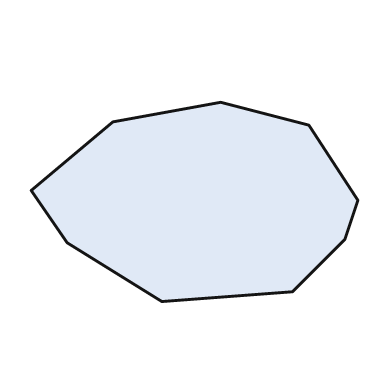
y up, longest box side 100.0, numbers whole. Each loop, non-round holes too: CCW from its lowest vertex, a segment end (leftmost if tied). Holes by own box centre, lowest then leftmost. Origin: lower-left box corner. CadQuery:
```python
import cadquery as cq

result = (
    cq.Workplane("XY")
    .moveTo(40.0, 0.0)
    .lineTo(80.0, 3.0)
    .lineTo(96.0, 19.0)
    .lineTo(100.0, 31.0)
    .lineTo(85.0, 54.0)
    .lineTo(58.0, 61.0)
    .lineTo(25.0, 55.0)
    .lineTo(0.0, 34.0)
    .lineTo(11.0, 18.0)
    .close()
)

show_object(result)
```